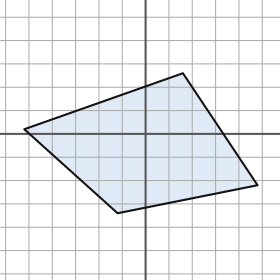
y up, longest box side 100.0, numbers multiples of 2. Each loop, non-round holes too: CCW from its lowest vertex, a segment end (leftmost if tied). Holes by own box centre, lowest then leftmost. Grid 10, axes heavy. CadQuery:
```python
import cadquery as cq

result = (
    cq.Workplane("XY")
    .moveTo(-12.0, -34.0)
    .lineTo(48.0, -22.0)
    .lineTo(16.0, 26.0)
    .lineTo(-52.0, 2.0)
    .close()
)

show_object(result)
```